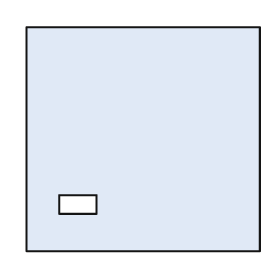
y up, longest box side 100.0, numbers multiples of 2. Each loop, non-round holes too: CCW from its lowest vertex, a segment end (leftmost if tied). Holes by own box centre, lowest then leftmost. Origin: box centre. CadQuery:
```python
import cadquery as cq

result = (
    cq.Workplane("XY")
    .moveTo(-50.0, -48.0)
    .lineTo(50.0, -48.0)
    .lineTo(50.0, 48.0)
    .lineTo(-50.0, 48.0)
    .close()
    .moveTo(-36.0, -32.0)
    .lineTo(-20.0, -32.0)
    .lineTo(-20.0, -24.0)
    .lineTo(-36.0, -24.0)
    .close()
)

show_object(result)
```